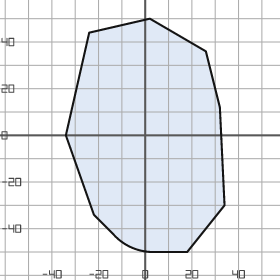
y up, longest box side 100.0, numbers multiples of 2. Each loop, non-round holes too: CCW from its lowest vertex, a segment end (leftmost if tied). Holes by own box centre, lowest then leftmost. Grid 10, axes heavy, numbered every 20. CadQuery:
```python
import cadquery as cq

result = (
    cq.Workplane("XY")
    .moveTo(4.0, -50.0)
    .lineTo(18.0, -50.0)
    .lineTo(34.0, -30.0)
    .lineTo(32.0, 12.0)
    .lineTo(26.0, 36.0)
    .lineTo(2.0, 50.0)
    .lineTo(-24.0, 44.0)
    .lineTo(-34.0, 0.0)
    .lineTo(-22.0, -34.0)
    .lineTo(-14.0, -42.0)
    .threePointArc((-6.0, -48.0), (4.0, -50.0))
    .close()
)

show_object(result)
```